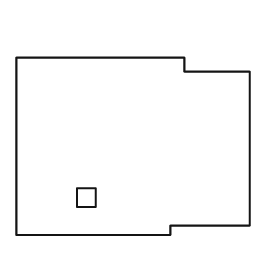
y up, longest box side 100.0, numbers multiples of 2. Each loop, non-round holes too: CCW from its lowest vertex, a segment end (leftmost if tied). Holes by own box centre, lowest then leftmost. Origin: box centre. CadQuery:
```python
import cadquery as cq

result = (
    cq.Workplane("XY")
    .moveTo(-50.0, -38.0)
    .lineTo(16.0, -38.0)
    .lineTo(16.0, -34.0)
    .lineTo(50.0, -34.0)
    .lineTo(50.0, 32.0)
    .lineTo(22.0, 32.0)
    .lineTo(22.0, 38.0)
    .lineTo(-50.0, 38.0)
    .close()
    .moveTo(-24.0, -26.0)
    .lineTo(-16.0, -26.0)
    .lineTo(-16.0, -18.0)
    .lineTo(-24.0, -18.0)
    .close()
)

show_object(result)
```